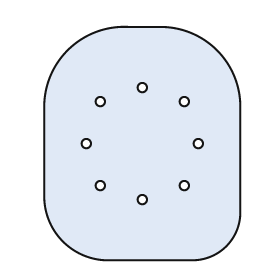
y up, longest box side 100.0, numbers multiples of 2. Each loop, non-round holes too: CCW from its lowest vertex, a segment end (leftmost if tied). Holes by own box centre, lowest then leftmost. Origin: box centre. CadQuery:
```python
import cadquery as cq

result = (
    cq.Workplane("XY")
    .moveTo(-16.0, -50.0)
    .lineTo(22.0, -50.0)
    .threePointArc((36.0, -44.0), (42.0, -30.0))
    .lineTo(42.0, 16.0)
    .threePointArc((32.0, 40.0), (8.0, 50.0))
    .lineTo(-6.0, 50.0)
    .threePointArc((-32.0, 40.0), (-42.0, 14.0))
    .lineTo(-42.0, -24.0)
    .threePointArc((-34.0, -42.0), (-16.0, -50.0))
    .close()
    .moveTo(0.0, -24.0)
    .circle(2.0)
    .moveTo(-18.0, -18.0)
    .circle(2.0)
    .moveTo(18.0, -18.0)
    .circle(2.0)
    .moveTo(-24.0, 0.0)
    .circle(2.0)
    .moveTo(24.0, 0.0)
    .circle(2.0)
    .moveTo(-18.0, 18.0)
    .circle(2.0)
    .moveTo(18.0, 18.0)
    .circle(2.0)
    .moveTo(0.0, 24.0)
    .circle(2.0)
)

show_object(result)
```